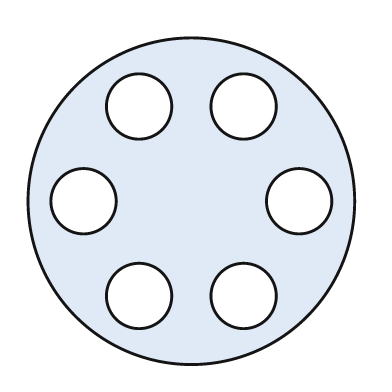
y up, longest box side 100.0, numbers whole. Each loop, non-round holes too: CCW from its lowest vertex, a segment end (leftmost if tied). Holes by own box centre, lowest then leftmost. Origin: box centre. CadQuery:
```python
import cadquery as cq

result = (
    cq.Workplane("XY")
    .moveTo(0.0, 0.0)
    .circle(50.0)
    .moveTo(-16.0, -29.0)
    .circle(10.0)
    .moveTo(16.0, -29.0)
    .circle(10.0)
    .moveTo(-33.0, 0.0)
    .circle(10.0)
    .moveTo(33.0, 0.0)
    .circle(10.0)
    .moveTo(-16.0, 29.0)
    .circle(10.0)
    .moveTo(16.0, 29.0)
    .circle(10.0)
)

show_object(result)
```